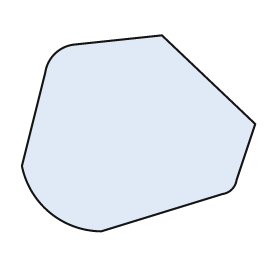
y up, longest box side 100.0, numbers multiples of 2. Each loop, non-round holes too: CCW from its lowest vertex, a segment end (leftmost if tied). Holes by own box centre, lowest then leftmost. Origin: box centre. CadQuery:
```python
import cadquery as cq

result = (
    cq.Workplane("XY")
    .moveTo(-16.0, -42.0)
    .lineTo(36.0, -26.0)
    .threePointArc((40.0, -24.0), (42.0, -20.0))
    .lineTo(50.0, 4.0)
    .lineTo(10.0, 42.0)
    .lineTo(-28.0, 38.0)
    .threePointArc((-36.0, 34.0), (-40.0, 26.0))
    .lineTo(-50.0, -14.0)
    .threePointArc((-38.0, -34.0), (-16.0, -42.0))
    .close()
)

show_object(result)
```